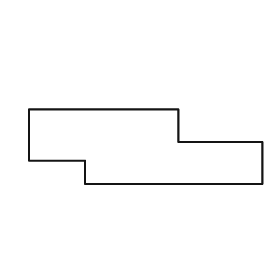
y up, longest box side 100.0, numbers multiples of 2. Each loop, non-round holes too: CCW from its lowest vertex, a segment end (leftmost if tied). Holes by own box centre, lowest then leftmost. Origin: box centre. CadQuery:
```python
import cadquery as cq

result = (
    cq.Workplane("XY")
    .moveTo(-26.0, -16.0)
    .lineTo(50.0, -16.0)
    .lineTo(50.0, 2.0)
    .lineTo(14.0, 2.0)
    .lineTo(14.0, 16.0)
    .lineTo(-50.0, 16.0)
    .lineTo(-50.0, -6.0)
    .lineTo(-26.0, -6.0)
    .close()
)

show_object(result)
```